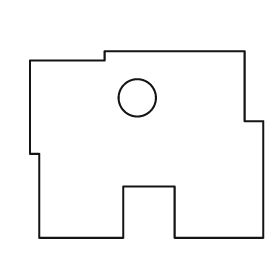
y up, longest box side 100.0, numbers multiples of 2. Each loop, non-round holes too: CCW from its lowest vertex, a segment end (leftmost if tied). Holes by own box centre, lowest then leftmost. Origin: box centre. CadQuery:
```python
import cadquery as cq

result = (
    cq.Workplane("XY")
    .moveTo(-46.0, -40.0)
    .lineTo(-10.0, -40.0)
    .lineTo(-10.0, -18.0)
    .lineTo(12.0, -18.0)
    .lineTo(12.0, -40.0)
    .lineTo(50.0, -40.0)
    .lineTo(50.0, 10.0)
    .lineTo(42.0, 10.0)
    .lineTo(42.0, 40.0)
    .lineTo(-18.0, 40.0)
    .lineTo(-18.0, 36.0)
    .lineTo(-50.0, 36.0)
    .lineTo(-50.0, -4.0)
    .lineTo(-46.0, -4.0)
    .close()
    .moveTo(-4.0, 20.0)
    .circle(8.0)
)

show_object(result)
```